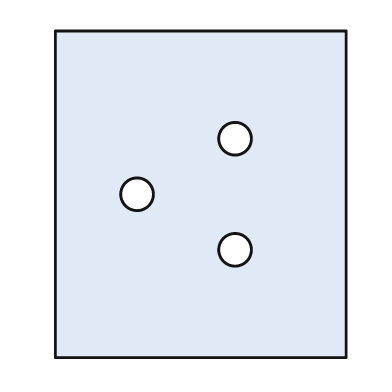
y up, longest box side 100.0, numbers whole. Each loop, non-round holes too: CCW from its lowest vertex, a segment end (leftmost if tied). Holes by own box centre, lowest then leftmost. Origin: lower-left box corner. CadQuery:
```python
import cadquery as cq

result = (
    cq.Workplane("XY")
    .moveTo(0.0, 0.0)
    .lineTo(89.0, 0.0)
    .lineTo(89.0, 100.0)
    .lineTo(0.0, 100.0)
    .close()
    .moveTo(55.0, 33.0)
    .circle(5.0)
    .moveTo(25.0, 50.0)
    .circle(5.0)
    .moveTo(55.0, 67.0)
    .circle(5.0)
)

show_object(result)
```